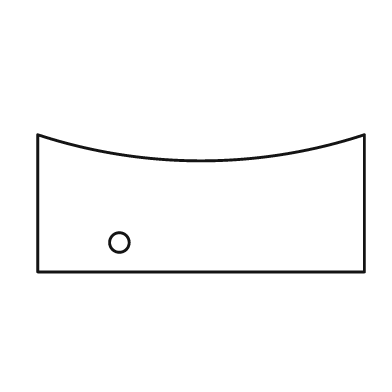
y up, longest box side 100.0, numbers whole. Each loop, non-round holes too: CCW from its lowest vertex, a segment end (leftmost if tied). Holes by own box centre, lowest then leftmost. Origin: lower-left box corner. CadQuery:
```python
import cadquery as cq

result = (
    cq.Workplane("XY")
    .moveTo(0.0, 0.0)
    .lineTo(100.0, 0.0)
    .lineTo(100.0, 42.0)
    .threePointArc((50.0, 34.0), (0.0, 42.0))
    .close()
    .moveTo(25.0, 9.0)
    .circle(3.0)
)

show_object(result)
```